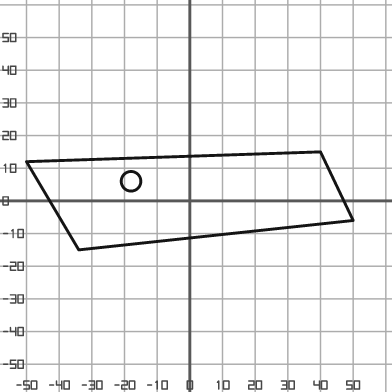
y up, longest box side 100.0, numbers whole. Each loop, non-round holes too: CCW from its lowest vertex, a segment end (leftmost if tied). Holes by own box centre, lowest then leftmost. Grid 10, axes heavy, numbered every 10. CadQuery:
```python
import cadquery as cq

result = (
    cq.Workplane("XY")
    .moveTo(-34.0, -15.0)
    .lineTo(50.0, -6.0)
    .lineTo(40.0, 15.0)
    .lineTo(-50.0, 12.0)
    .close()
    .moveTo(-18.0, 6.0)
    .circle(3.0)
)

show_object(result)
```